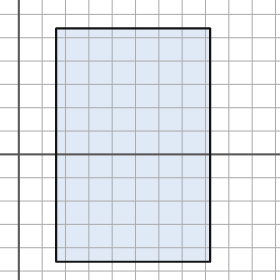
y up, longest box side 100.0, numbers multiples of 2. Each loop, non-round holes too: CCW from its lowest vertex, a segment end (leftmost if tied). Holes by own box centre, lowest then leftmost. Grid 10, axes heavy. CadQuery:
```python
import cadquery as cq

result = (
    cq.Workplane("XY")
    .moveTo(16.0, -46.0)
    .lineTo(82.0, -46.0)
    .lineTo(82.0, 54.0)
    .lineTo(16.0, 54.0)
    .close()
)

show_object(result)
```